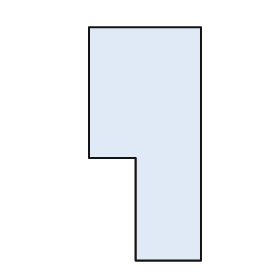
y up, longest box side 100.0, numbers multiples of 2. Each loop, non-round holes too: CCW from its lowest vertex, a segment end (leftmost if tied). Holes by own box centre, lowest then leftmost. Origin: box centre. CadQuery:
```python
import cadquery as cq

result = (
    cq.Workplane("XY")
    .moveTo(-4.0, -50.0)
    .lineTo(24.0, -50.0)
    .lineTo(24.0, 50.0)
    .lineTo(-24.0, 50.0)
    .lineTo(-24.0, -6.0)
    .lineTo(-4.0, -6.0)
    .close()
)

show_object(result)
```